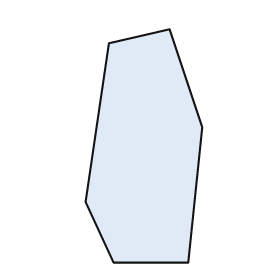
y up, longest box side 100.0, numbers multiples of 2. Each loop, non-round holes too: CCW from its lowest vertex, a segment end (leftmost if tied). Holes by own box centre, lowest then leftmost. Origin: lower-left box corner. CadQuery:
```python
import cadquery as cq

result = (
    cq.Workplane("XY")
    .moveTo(12.0, 0.0)
    .lineTo(44.0, 0.0)
    .lineTo(50.0, 58.0)
    .lineTo(36.0, 100.0)
    .lineTo(10.0, 94.0)
    .lineTo(0.0, 26.0)
    .close()
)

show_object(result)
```